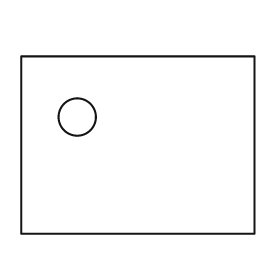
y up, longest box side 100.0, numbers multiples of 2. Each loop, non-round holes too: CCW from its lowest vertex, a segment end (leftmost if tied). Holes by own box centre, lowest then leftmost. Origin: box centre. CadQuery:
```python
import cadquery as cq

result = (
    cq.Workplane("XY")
    .moveTo(-50.0, -38.0)
    .lineTo(50.0, -38.0)
    .lineTo(50.0, 38.0)
    .lineTo(-50.0, 38.0)
    .close()
    .moveTo(-26.0, 12.0)
    .circle(8.0)
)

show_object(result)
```